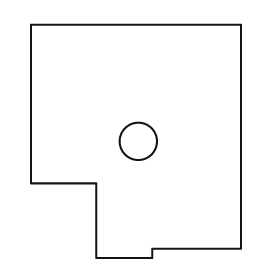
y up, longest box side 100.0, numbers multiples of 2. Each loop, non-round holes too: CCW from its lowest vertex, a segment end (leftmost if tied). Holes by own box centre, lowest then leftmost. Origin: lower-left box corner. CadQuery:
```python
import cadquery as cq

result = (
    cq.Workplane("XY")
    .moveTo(28.0, 0.0)
    .lineTo(52.0, 0.0)
    .lineTo(52.0, 4.0)
    .lineTo(90.0, 4.0)
    .lineTo(90.0, 100.0)
    .lineTo(0.0, 100.0)
    .lineTo(0.0, 32.0)
    .lineTo(28.0, 32.0)
    .close()
    .moveTo(46.0, 50.0)
    .circle(8.0)
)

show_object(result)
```